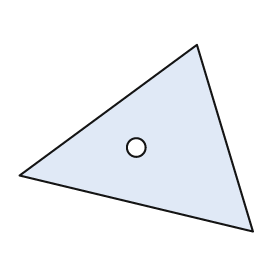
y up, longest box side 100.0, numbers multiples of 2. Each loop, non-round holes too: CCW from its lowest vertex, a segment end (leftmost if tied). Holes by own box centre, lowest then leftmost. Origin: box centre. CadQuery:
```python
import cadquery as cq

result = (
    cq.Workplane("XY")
    .moveTo(50.0, -40.0)
    .lineTo(26.0, 40.0)
    .lineTo(-50.0, -16.0)
    .close()
    .moveTo(0.0, -4.0)
    .circle(4.0)
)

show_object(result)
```